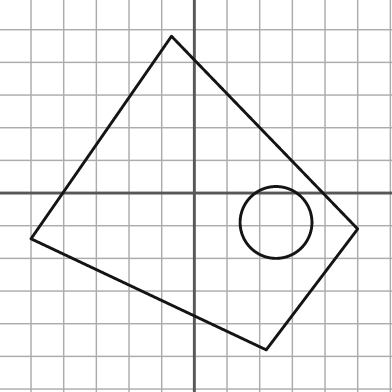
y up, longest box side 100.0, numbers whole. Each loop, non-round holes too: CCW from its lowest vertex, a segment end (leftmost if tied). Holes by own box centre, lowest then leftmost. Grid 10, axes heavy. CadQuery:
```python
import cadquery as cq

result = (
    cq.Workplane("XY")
    .moveTo(22.0, -48.0)
    .lineTo(50.0, -11.0)
    .lineTo(-7.0, 48.0)
    .lineTo(-50.0, -14.0)
    .close()
    .moveTo(25.0, -9.0)
    .circle(11.0)
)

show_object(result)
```